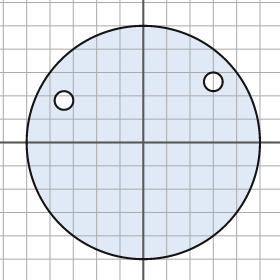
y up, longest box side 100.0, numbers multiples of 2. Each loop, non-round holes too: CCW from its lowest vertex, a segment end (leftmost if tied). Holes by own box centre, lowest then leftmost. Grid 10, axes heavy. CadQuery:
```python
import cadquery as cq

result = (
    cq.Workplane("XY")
    .moveTo(0.0, 0.0)
    .circle(50.0)
    .moveTo(-34.0, 18.0)
    .circle(4.0)
    .moveTo(30.0, 26.0)
    .circle(4.0)
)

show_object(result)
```